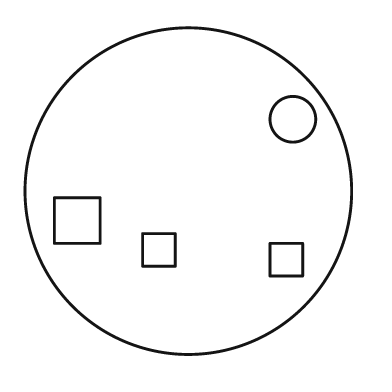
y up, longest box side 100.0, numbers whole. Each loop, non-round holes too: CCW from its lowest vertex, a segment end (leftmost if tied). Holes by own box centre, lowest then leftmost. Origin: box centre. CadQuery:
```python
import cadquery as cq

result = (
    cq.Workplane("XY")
    .moveTo(0.0, 0.0)
    .circle(50.0)
    .moveTo(25.0, -26.0)
    .lineTo(35.0, -26.0)
    .lineTo(35.0, -16.0)
    .lineTo(25.0, -16.0)
    .close()
    .moveTo(-14.0, -23.0)
    .lineTo(-4.0, -23.0)
    .lineTo(-4.0, -13.0)
    .lineTo(-14.0, -13.0)
    .close()
    .moveTo(-41.0, -16.0)
    .lineTo(-27.0, -16.0)
    .lineTo(-27.0, -2.0)
    .lineTo(-41.0, -2.0)
    .close()
    .moveTo(32.0, 22.0)
    .circle(7.0)
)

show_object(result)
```